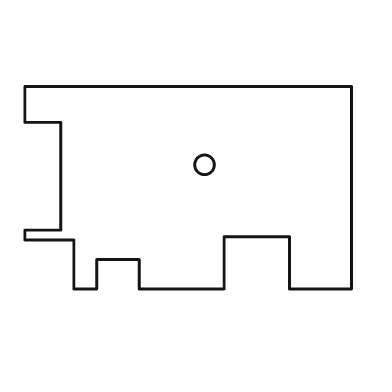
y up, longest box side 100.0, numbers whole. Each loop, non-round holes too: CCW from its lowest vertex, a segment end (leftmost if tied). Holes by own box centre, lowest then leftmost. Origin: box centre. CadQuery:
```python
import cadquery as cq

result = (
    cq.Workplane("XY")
    .moveTo(-35.0, -31.0)
    .lineTo(-28.0, -31.0)
    .lineTo(-28.0, -22.0)
    .lineTo(-15.0, -22.0)
    .lineTo(-15.0, -31.0)
    .lineTo(11.0, -31.0)
    .lineTo(11.0, -15.0)
    .lineTo(31.0, -15.0)
    .lineTo(31.0, -31.0)
    .lineTo(50.0, -31.0)
    .lineTo(50.0, 31.0)
    .lineTo(-50.0, 31.0)
    .lineTo(-50.0, 20.0)
    .lineTo(-39.0, 20.0)
    .lineTo(-39.0, -13.0)
    .lineTo(-50.0, -13.0)
    .lineTo(-50.0, -16.0)
    .lineTo(-35.0, -16.0)
    .close()
    .moveTo(5.0, 7.0)
    .circle(3.0)
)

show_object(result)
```